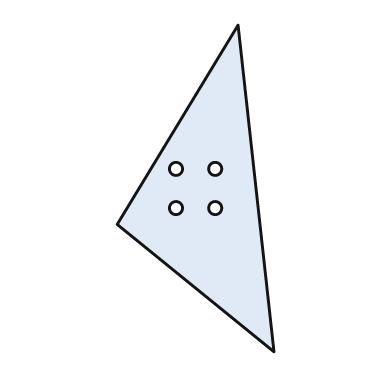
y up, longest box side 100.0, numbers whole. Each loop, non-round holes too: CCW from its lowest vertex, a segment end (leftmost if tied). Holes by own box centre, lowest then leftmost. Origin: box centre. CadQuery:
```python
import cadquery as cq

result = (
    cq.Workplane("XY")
    .moveTo(24.0, -50.0)
    .lineTo(13.0, 50.0)
    .lineTo(-24.0, -11.0)
    .close()
    .moveTo(-6.0, -6.0)
    .circle(2.0)
    .moveTo(6.0, -6.0)
    .circle(2.0)
    .moveTo(-6.0, 6.0)
    .circle(2.0)
    .moveTo(6.0, 6.0)
    .circle(2.0)
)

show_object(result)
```